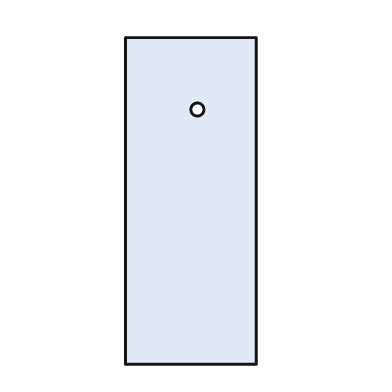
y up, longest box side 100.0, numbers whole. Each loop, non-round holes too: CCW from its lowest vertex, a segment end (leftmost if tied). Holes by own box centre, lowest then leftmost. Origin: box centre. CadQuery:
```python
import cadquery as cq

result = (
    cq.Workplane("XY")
    .moveTo(-20.0, -50.0)
    .lineTo(20.0, -50.0)
    .lineTo(20.0, 50.0)
    .lineTo(-20.0, 50.0)
    .close()
    .moveTo(2.0, 28.0)
    .circle(2.0)
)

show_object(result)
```